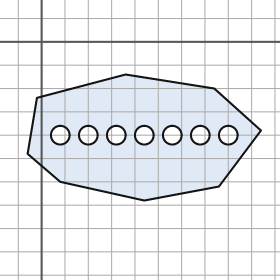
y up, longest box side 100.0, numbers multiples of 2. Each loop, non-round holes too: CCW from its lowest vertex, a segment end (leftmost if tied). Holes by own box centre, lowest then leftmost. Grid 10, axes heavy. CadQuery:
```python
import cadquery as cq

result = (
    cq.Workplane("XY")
    .moveTo(44.0, -68.0)
    .lineTo(76.0, -62.0)
    .lineTo(94.0, -38.0)
    .lineTo(74.0, -20.0)
    .lineTo(36.0, -14.0)
    .lineTo(-2.0, -24.0)
    .lineTo(-6.0, -48.0)
    .lineTo(8.0, -60.0)
    .close()
    .moveTo(8.0, -40.0)
    .circle(4.0)
    .moveTo(20.0, -40.0)
    .circle(4.0)
    .moveTo(32.0, -40.0)
    .circle(4.0)
    .moveTo(44.0, -40.0)
    .circle(4.0)
    .moveTo(56.0, -40.0)
    .circle(4.0)
    .moveTo(68.0, -40.0)
    .circle(4.0)
    .moveTo(80.0, -40.0)
    .circle(4.0)
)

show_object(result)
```